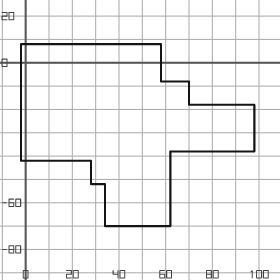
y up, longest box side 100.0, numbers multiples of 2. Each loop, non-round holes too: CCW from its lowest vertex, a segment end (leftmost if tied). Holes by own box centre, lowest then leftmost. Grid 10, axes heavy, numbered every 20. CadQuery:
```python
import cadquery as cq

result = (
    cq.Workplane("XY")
    .moveTo(34.0, -70.0)
    .lineTo(62.0, -70.0)
    .lineTo(62.0, -38.0)
    .lineTo(98.0, -38.0)
    .lineTo(98.0, -18.0)
    .lineTo(70.0, -18.0)
    .lineTo(70.0, -8.0)
    .lineTo(58.0, -8.0)
    .lineTo(58.0, 8.0)
    .lineTo(-2.0, 8.0)
    .lineTo(-2.0, -42.0)
    .lineTo(28.0, -42.0)
    .lineTo(28.0, -52.0)
    .lineTo(34.0, -52.0)
    .close()
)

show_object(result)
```